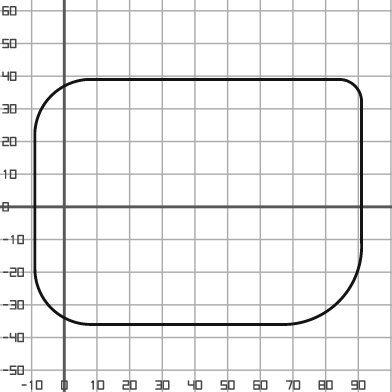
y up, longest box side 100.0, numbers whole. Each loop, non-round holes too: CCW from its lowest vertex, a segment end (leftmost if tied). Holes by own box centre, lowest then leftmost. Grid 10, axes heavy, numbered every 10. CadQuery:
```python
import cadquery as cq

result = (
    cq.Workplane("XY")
    .moveTo(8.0, -36.0)
    .lineTo(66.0, -36.0)
    .threePointArc((84.0, -29.0), (91.0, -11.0))
    .lineTo(91.0, 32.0)
    .threePointArc((89.0, 37.0), (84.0, 39.0))
    .lineTo(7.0, 39.0)
    .threePointArc((-4.0, 34.0), (-9.0, 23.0))
    .lineTo(-9.0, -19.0)
    .threePointArc((-4.0, -31.0), (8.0, -36.0))
    .close()
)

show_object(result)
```